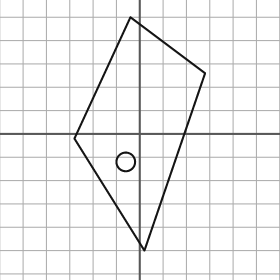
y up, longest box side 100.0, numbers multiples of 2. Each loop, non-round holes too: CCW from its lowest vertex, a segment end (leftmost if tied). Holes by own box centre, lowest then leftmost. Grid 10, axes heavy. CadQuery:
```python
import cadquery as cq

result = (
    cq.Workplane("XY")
    .moveTo(2.0, -50.0)
    .lineTo(28.0, 26.0)
    .lineTo(-4.0, 50.0)
    .lineTo(-28.0, -2.0)
    .close()
    .moveTo(-6.0, -12.0)
    .circle(4.0)
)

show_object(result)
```